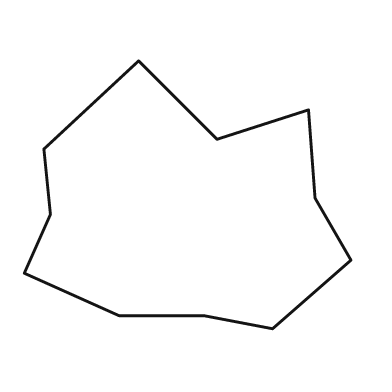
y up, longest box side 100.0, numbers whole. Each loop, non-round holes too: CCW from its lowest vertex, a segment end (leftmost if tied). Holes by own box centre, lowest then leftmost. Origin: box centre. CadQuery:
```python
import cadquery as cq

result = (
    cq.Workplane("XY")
    .moveTo(26.0, -41.0)
    .lineTo(50.0, -20.0)
    .lineTo(39.0, -1.0)
    .lineTo(37.0, 26.0)
    .lineTo(9.0, 17.0)
    .lineTo(-15.0, 41.0)
    .lineTo(-44.0, 14.0)
    .lineTo(-42.0, -6.0)
    .lineTo(-50.0, -24.0)
    .lineTo(-21.0, -37.0)
    .lineTo(5.0, -37.0)
    .close()
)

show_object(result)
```